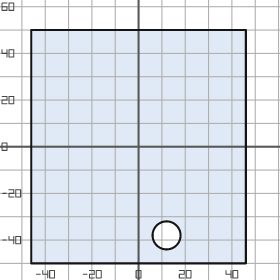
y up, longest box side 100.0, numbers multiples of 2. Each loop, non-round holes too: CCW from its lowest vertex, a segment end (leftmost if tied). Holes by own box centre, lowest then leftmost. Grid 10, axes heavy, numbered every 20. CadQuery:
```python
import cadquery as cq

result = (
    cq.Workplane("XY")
    .moveTo(-46.0, -50.0)
    .lineTo(46.0, -50.0)
    .lineTo(46.0, 50.0)
    .lineTo(-46.0, 50.0)
    .close()
    .moveTo(12.0, -38.0)
    .circle(6.0)
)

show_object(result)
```